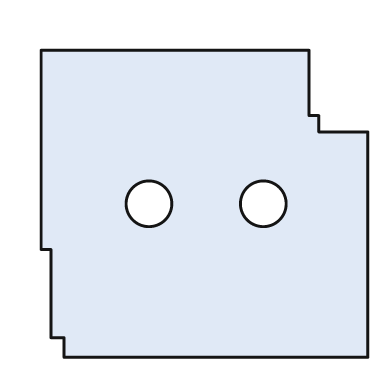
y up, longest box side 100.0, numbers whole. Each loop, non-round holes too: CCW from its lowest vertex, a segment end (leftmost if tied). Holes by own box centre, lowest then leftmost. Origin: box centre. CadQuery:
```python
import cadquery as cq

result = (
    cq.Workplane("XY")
    .moveTo(-43.0, -47.0)
    .lineTo(50.0, -47.0)
    .lineTo(50.0, 22.0)
    .lineTo(35.0, 22.0)
    .lineTo(35.0, 27.0)
    .lineTo(32.0, 27.0)
    .lineTo(32.0, 47.0)
    .lineTo(-50.0, 47.0)
    .lineTo(-50.0, -14.0)
    .lineTo(-47.0, -14.0)
    .lineTo(-47.0, -41.0)
    .lineTo(-43.0, -41.0)
    .close()
    .moveTo(-17.0, 0.0)
    .circle(7.0)
    .moveTo(18.0, 0.0)
    .circle(7.0)
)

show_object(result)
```